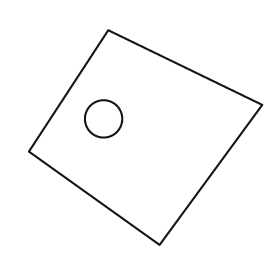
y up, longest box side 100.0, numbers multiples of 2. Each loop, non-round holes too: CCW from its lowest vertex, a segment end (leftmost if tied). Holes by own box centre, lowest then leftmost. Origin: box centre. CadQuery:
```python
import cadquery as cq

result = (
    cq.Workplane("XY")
    .moveTo(6.0, -46.0)
    .lineTo(50.0, 14.0)
    .lineTo(-16.0, 46.0)
    .lineTo(-50.0, -6.0)
    .close()
    .moveTo(-18.0, 8.0)
    .circle(8.0)
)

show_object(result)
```